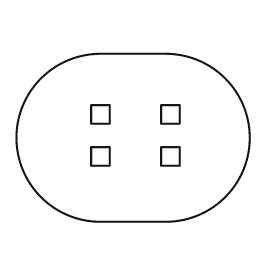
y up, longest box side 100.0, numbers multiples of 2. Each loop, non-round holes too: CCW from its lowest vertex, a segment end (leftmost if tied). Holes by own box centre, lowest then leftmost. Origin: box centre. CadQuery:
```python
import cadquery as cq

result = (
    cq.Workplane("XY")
    .moveTo(-14.0, -36.0)
    .lineTo(14.0, -36.0)
    .threePointArc((50.0, 0.0), (14.0, 36.0))
    .lineTo(-14.0, 36.0)
    .threePointArc((-50.0, 0.0), (-14.0, -36.0))
    .close()
    .moveTo(-18.0, -12.0)
    .lineTo(-10.0, -12.0)
    .lineTo(-10.0, -4.0)
    .lineTo(-18.0, -4.0)
    .close()
    .moveTo(12.0, -12.0)
    .lineTo(20.0, -12.0)
    .lineTo(20.0, -4.0)
    .lineTo(12.0, -4.0)
    .close()
    .moveTo(-18.0, 6.0)
    .lineTo(-10.0, 6.0)
    .lineTo(-10.0, 14.0)
    .lineTo(-18.0, 14.0)
    .close()
    .moveTo(12.0, 6.0)
    .lineTo(20.0, 6.0)
    .lineTo(20.0, 14.0)
    .lineTo(12.0, 14.0)
    .close()
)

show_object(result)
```